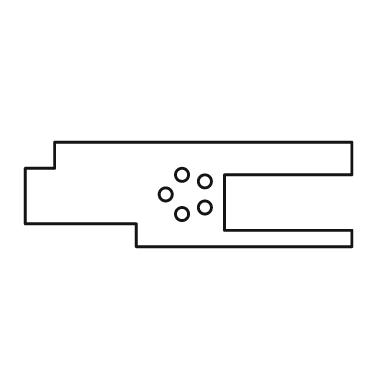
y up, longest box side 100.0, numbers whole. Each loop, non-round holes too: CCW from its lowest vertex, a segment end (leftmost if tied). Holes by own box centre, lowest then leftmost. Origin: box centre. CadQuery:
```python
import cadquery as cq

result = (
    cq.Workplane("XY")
    .moveTo(-16.0, -16.0)
    .lineTo(50.0, -16.0)
    .lineTo(50.0, -11.0)
    .lineTo(11.0, -11.0)
    .lineTo(11.0, 6.0)
    .lineTo(50.0, 6.0)
    .lineTo(50.0, 16.0)
    .lineTo(-41.0, 16.0)
    .lineTo(-41.0, 8.0)
    .lineTo(-50.0, 8.0)
    .lineTo(-50.0, -9.0)
    .lineTo(-16.0, -9.0)
    .close()
    .moveTo(-2.0, -6.0)
    .circle(2.0)
    .moveTo(5.0, -4.0)
    .circle(2.0)
    .moveTo(-7.0, 0.0)
    .circle(2.0)
    .moveTo(5.0, 4.0)
    .circle(2.0)
    .moveTo(-2.0, 6.0)
    .circle(2.0)
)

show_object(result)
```